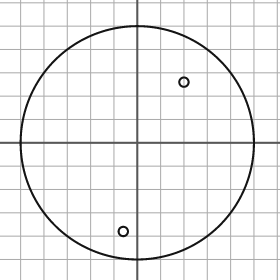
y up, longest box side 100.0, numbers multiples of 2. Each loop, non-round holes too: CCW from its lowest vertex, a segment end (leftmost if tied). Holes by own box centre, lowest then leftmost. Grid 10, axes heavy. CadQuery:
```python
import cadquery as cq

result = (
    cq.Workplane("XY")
    .moveTo(0.0, 0.0)
    .circle(50.0)
    .moveTo(-6.0, -38.0)
    .circle(2.0)
    .moveTo(20.0, 26.0)
    .circle(2.0)
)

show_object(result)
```